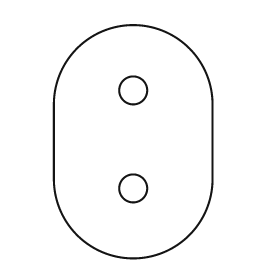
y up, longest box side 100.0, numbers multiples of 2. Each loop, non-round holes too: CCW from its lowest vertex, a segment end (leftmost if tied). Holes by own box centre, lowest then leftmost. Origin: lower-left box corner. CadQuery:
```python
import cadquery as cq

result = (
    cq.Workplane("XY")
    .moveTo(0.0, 34.0)
    .threePointArc((34.0, 0.0), (68.0, 34.0))
    .lineTo(68.0, 66.0)
    .threePointArc((34.0, 100.0), (0.0, 66.0))
    .close()
    .moveTo(34.0, 30.0)
    .circle(6.0)
    .moveTo(34.0, 72.0)
    .circle(6.0)
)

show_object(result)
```